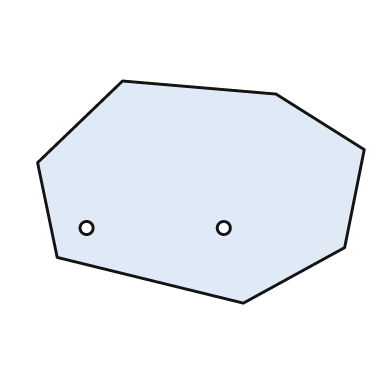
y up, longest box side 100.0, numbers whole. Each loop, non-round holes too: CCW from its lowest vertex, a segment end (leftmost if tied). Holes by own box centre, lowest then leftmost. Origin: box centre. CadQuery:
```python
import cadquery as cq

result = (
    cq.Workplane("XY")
    .moveTo(13.0, -34.0)
    .lineTo(44.0, -17.0)
    .lineTo(50.0, 13.0)
    .lineTo(23.0, 30.0)
    .lineTo(-24.0, 34.0)
    .lineTo(-50.0, 9.0)
    .lineTo(-44.0, -20.0)
    .close()
    .moveTo(-35.0, -11.0)
    .circle(2.0)
    .moveTo(7.0, -11.0)
    .circle(2.0)
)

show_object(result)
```